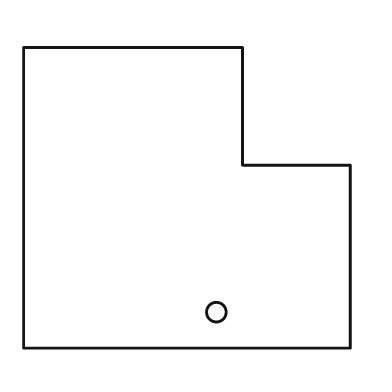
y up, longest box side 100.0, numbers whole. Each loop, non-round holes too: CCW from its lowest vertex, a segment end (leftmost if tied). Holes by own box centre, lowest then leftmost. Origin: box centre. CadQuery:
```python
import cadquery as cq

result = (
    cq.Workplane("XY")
    .moveTo(-50.0, -46.0)
    .lineTo(50.0, -46.0)
    .lineTo(50.0, 10.0)
    .lineTo(17.0, 10.0)
    .lineTo(17.0, 46.0)
    .lineTo(-50.0, 46.0)
    .close()
    .moveTo(9.0, -35.0)
    .circle(3.0)
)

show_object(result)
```